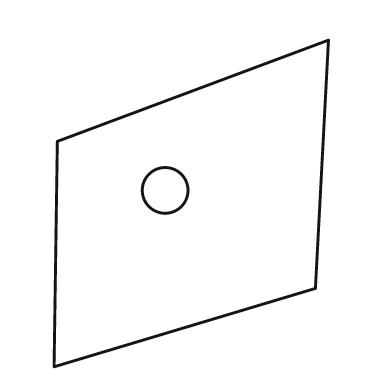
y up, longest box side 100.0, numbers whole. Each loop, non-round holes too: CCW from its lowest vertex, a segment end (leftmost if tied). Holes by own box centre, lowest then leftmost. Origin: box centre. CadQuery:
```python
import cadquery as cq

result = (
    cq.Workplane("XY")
    .moveTo(-42.0, -50.0)
    .lineTo(38.0, -26.0)
    .lineTo(42.0, 50.0)
    .lineTo(-41.0, 19.0)
    .close()
    .moveTo(-8.0, 4.0)
    .circle(7.0)
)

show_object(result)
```